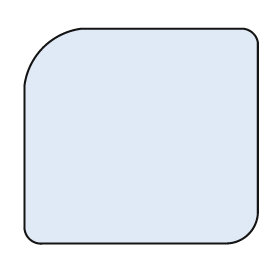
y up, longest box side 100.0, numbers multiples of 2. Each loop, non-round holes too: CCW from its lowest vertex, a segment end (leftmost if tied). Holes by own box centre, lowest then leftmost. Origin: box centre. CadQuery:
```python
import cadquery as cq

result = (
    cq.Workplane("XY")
    .moveTo(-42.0, -46.0)
    .lineTo(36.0, -46.0)
    .threePointArc((46.0, -42.0), (50.0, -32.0))
    .lineTo(50.0, 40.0)
    .threePointArc((48.0, 44.0), (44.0, 46.0))
    .lineTo(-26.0, 46.0)
    .threePointArc((-42.0, 38.0), (-50.0, 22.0))
    .lineTo(-50.0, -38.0)
    .threePointArc((-48.0, -44.0), (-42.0, -46.0))
    .close()
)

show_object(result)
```